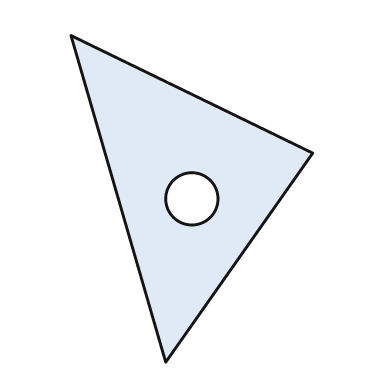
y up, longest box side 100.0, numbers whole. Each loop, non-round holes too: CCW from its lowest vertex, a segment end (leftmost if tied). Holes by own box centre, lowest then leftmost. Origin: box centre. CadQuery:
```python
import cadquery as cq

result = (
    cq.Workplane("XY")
    .moveTo(-8.0, -50.0)
    .lineTo(37.0, 14.0)
    .lineTo(-37.0, 50.0)
    .close()
    .moveTo(0.0, 0.0)
    .circle(8.0)
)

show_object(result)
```